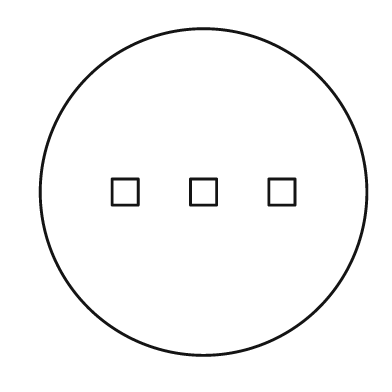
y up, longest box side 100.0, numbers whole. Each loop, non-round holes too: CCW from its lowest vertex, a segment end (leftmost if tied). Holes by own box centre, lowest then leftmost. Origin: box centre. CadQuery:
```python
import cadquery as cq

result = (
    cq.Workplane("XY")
    .moveTo(0.0, 0.0)
    .circle(50.0)
    .moveTo(-28.0, -4.0)
    .lineTo(-20.0, -4.0)
    .lineTo(-20.0, 4.0)
    .lineTo(-28.0, 4.0)
    .close()
    .moveTo(-4.0, -4.0)
    .lineTo(4.0, -4.0)
    .lineTo(4.0, 4.0)
    .lineTo(-4.0, 4.0)
    .close()
    .moveTo(20.0, -4.0)
    .lineTo(28.0, -4.0)
    .lineTo(28.0, 4.0)
    .lineTo(20.0, 4.0)
    .close()
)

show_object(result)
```